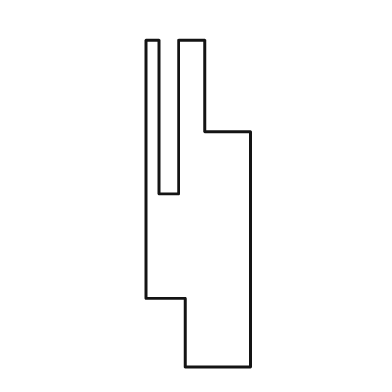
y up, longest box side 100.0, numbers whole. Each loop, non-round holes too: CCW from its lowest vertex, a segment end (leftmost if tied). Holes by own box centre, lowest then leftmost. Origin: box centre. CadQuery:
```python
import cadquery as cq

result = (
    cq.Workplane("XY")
    .moveTo(-4.0, -50.0)
    .lineTo(16.0, -50.0)
    .lineTo(16.0, 22.0)
    .lineTo(2.0, 22.0)
    .lineTo(2.0, 50.0)
    .lineTo(-6.0, 50.0)
    .lineTo(-6.0, 3.0)
    .lineTo(-12.0, 3.0)
    .lineTo(-12.0, 50.0)
    .lineTo(-16.0, 50.0)
    .lineTo(-16.0, -29.0)
    .lineTo(-4.0, -29.0)
    .close()
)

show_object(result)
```